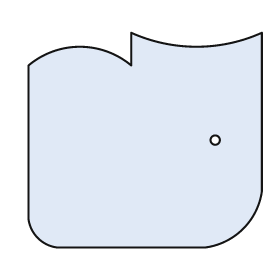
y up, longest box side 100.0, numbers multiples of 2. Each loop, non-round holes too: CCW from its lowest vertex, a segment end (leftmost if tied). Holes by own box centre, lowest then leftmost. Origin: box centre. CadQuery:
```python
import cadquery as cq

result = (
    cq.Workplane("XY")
    .moveTo(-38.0, -46.0)
    .lineTo(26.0, -46.0)
    .threePointArc((42.0, -38.0), (50.0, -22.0))
    .lineTo(50.0, 46.0)
    .threePointArc((22.0, 40.0), (-6.0, 46.0))
    .lineTo(-6.0, 32.0)
    .threePointArc((-28.0, 40.0), (-50.0, 32.0))
    .lineTo(-50.0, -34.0)
    .threePointArc((-46.0, -42.0), (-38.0, -46.0))
    .close()
    .moveTo(30.0, 0.0)
    .circle(2.0)
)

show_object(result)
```